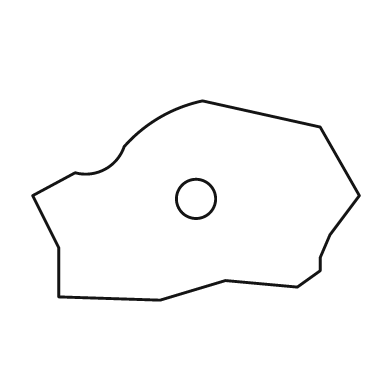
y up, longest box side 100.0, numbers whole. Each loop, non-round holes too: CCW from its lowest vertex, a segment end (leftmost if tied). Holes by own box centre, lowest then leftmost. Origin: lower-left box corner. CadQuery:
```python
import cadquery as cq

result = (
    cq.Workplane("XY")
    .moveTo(39.0, 0.0)
    .lineTo(59.0, 6.0)
    .lineTo(81.0, 4.0)
    .lineTo(88.0, 9.0)
    .lineTo(88.0, 13.0)
    .lineTo(91.0, 20.0)
    .lineTo(100.0, 32.0)
    .lineTo(88.0, 53.0)
    .lineTo(52.0, 61.0)
    .threePointArc((39.0, 56.0), (28.0, 47.0))
    .threePointArc((22.0, 40.0), (13.0, 39.0))
    .lineTo(0.0, 32.0)
    .lineTo(8.0, 16.0)
    .lineTo(8.0, 1.0)
    .close()
    .moveTo(50.0, 31.0)
    .circle(6.0)
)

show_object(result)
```